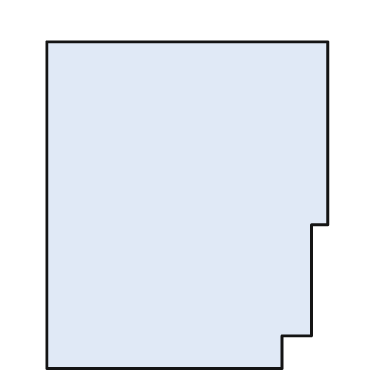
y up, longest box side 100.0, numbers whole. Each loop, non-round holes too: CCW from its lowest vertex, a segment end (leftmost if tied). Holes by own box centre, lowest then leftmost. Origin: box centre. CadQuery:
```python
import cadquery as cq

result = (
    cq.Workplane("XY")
    .moveTo(-43.0, -50.0)
    .lineTo(29.0, -50.0)
    .lineTo(29.0, -40.0)
    .lineTo(38.0, -40.0)
    .lineTo(38.0, -6.0)
    .lineTo(43.0, -6.0)
    .lineTo(43.0, 50.0)
    .lineTo(-43.0, 50.0)
    .close()
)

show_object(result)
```